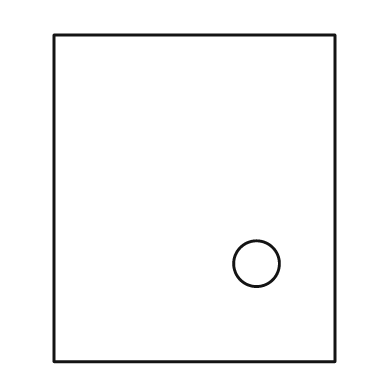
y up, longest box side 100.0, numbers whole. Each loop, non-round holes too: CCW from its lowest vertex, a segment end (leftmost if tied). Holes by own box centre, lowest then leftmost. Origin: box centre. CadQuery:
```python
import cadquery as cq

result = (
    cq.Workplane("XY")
    .moveTo(-43.0, -50.0)
    .lineTo(43.0, -50.0)
    .lineTo(43.0, 50.0)
    .lineTo(-43.0, 50.0)
    .close()
    .moveTo(19.0, -20.0)
    .circle(7.0)
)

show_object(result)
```